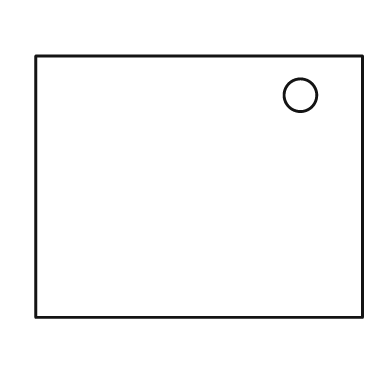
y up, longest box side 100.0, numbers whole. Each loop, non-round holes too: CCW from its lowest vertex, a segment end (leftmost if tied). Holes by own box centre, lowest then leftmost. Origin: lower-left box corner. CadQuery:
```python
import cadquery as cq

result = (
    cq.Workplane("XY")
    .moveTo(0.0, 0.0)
    .lineTo(100.0, 0.0)
    .lineTo(100.0, 80.0)
    .lineTo(0.0, 80.0)
    .close()
    .moveTo(81.0, 68.0)
    .circle(5.0)
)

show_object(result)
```